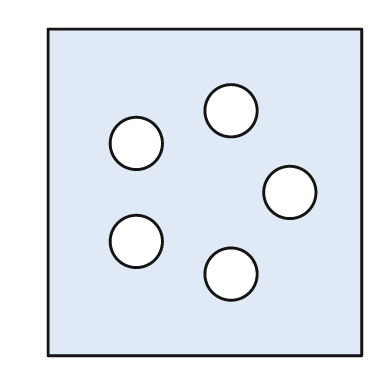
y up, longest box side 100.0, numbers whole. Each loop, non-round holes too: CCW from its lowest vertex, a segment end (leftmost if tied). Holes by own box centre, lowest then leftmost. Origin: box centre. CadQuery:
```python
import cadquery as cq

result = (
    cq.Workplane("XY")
    .moveTo(-48.0, -50.0)
    .lineTo(48.0, -50.0)
    .lineTo(48.0, 50.0)
    .lineTo(-48.0, 50.0)
    .close()
    .moveTo(8.0, -25.0)
    .circle(8.0)
    .moveTo(-21.0, -15.0)
    .circle(8.0)
    .moveTo(26.0, 0.0)
    .circle(8.0)
    .moveTo(-21.0, 15.0)
    .circle(8.0)
    .moveTo(8.0, 25.0)
    .circle(8.0)
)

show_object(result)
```